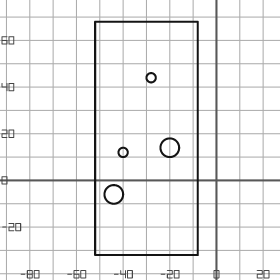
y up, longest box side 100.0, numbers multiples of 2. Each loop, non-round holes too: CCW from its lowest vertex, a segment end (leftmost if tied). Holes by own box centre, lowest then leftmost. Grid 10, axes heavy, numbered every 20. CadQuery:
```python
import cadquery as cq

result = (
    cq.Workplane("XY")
    .moveTo(-52.0, -32.0)
    .lineTo(-8.0, -32.0)
    .lineTo(-8.0, 68.0)
    .lineTo(-52.0, 68.0)
    .close()
    .moveTo(-44.0, -6.0)
    .circle(4.0)
    .moveTo(-40.0, 12.0)
    .circle(2.0)
    .moveTo(-20.0, 14.0)
    .circle(4.0)
    .moveTo(-28.0, 44.0)
    .circle(2.0)
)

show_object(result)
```